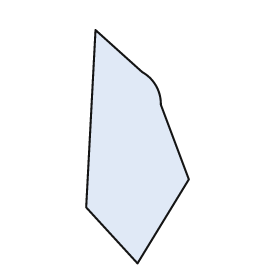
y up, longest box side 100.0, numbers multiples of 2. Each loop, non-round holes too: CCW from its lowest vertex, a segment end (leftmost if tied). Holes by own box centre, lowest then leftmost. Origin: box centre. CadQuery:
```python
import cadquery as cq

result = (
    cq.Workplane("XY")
    .moveTo(0.0, -50.0)
    .lineTo(22.0, -14.0)
    .lineTo(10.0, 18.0)
    .threePointArc((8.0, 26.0), (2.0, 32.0))
    .lineTo(-18.0, 50.0)
    .lineTo(-22.0, -26.0)
    .close()
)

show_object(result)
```